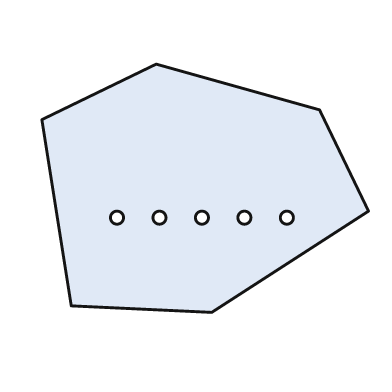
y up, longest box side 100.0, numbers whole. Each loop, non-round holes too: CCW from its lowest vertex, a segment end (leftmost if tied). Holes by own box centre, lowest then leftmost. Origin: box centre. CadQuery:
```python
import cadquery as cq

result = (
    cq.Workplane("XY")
    .moveTo(2.0, -38.0)
    .lineTo(50.0, -7.0)
    .lineTo(35.0, 24.0)
    .lineTo(-15.0, 38.0)
    .lineTo(-50.0, 21.0)
    .lineTo(-41.0, -36.0)
    .close()
    .moveTo(-27.0, -9.0)
    .circle(2.0)
    .moveTo(-14.0, -9.0)
    .circle(2.0)
    .moveTo(-1.0, -9.0)
    .circle(2.0)
    .moveTo(12.0, -9.0)
    .circle(2.0)
    .moveTo(25.0, -9.0)
    .circle(2.0)
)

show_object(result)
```